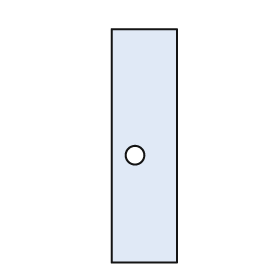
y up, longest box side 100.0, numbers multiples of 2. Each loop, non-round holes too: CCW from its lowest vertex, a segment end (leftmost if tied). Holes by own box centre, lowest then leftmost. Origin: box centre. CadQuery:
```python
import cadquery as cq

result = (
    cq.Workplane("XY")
    .moveTo(-14.0, -50.0)
    .lineTo(14.0, -50.0)
    .lineTo(14.0, 50.0)
    .lineTo(-14.0, 50.0)
    .close()
    .moveTo(-4.0, -4.0)
    .circle(4.0)
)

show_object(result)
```